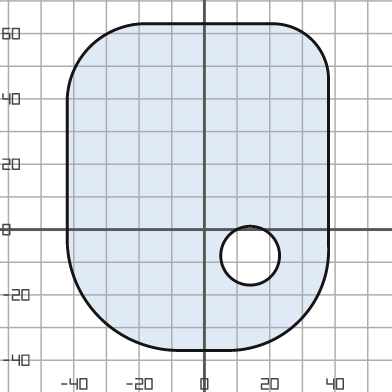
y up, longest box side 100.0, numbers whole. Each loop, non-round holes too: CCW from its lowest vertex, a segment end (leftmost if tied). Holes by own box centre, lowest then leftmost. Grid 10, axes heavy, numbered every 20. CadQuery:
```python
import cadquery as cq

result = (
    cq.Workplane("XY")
    .moveTo(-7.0, -37.0)
    .lineTo(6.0, -37.0)
    .threePointArc((29.0, -28.0), (38.0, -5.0))
    .lineTo(38.0, 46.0)
    .threePointArc((33.0, 58.0), (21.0, 63.0))
    .lineTo(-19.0, 63.0)
    .threePointArc((-35.0, 56.0), (-42.0, 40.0))
    .lineTo(-42.0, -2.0)
    .threePointArc((-32.0, -27.0), (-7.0, -37.0))
    .close()
    .moveTo(14.0, -8.0)
    .circle(9.0)
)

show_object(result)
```